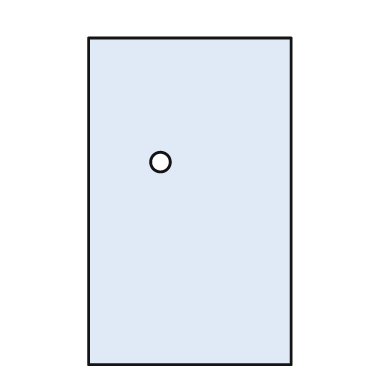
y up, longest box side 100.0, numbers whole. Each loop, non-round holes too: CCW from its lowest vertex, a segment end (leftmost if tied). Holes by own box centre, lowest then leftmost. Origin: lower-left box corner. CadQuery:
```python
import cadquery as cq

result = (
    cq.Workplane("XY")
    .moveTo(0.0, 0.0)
    .lineTo(62.0, 0.0)
    .lineTo(62.0, 100.0)
    .lineTo(0.0, 100.0)
    .close()
    .moveTo(22.0, 62.0)
    .circle(3.0)
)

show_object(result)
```